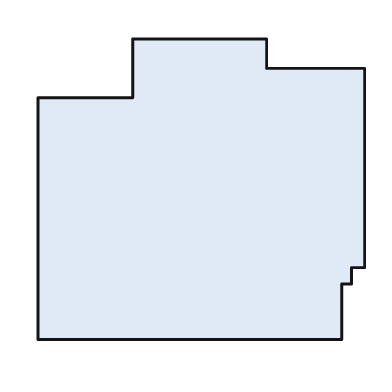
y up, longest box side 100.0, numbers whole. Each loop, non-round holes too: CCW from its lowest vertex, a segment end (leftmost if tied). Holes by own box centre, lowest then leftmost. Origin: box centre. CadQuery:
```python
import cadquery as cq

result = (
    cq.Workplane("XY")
    .moveTo(-50.0, -46.0)
    .lineTo(43.0, -46.0)
    .lineTo(43.0, -29.0)
    .lineTo(46.0, -29.0)
    .lineTo(46.0, -24.0)
    .lineTo(50.0, -24.0)
    .lineTo(50.0, 37.0)
    .lineTo(20.0, 37.0)
    .lineTo(20.0, 46.0)
    .lineTo(-21.0, 46.0)
    .lineTo(-21.0, 28.0)
    .lineTo(-50.0, 28.0)
    .close()
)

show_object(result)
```